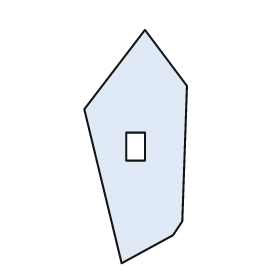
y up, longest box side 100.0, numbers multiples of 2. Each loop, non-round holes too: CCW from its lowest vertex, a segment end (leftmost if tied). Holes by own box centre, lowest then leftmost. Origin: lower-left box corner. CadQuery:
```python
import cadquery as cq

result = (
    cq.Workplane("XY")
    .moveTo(16.0, 0.0)
    .lineTo(38.0, 12.0)
    .lineTo(42.0, 18.0)
    .lineTo(44.0, 76.0)
    .lineTo(26.0, 100.0)
    .lineTo(0.0, 66.0)
    .close()
    .moveTo(18.0, 44.0)
    .lineTo(26.0, 44.0)
    .lineTo(26.0, 56.0)
    .lineTo(18.0, 56.0)
    .close()
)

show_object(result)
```